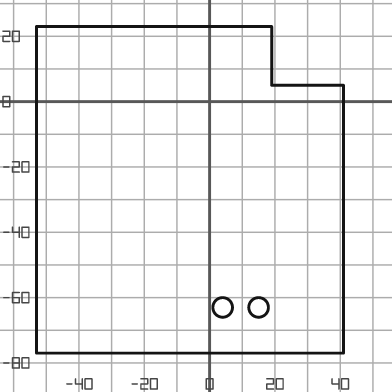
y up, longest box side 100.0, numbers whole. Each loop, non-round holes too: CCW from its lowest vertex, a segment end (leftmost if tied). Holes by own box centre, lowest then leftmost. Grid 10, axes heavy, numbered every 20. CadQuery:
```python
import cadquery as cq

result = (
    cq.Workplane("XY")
    .moveTo(-53.0, -77.0)
    .lineTo(41.0, -77.0)
    .lineTo(41.0, 5.0)
    .lineTo(19.0, 5.0)
    .lineTo(19.0, 23.0)
    .lineTo(-53.0, 23.0)
    .close()
    .moveTo(4.0, -63.0)
    .circle(3.0)
    .moveTo(15.0, -63.0)
    .circle(3.0)
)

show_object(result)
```